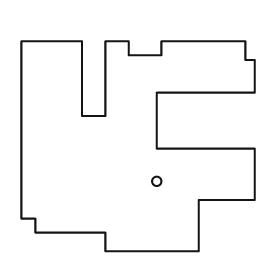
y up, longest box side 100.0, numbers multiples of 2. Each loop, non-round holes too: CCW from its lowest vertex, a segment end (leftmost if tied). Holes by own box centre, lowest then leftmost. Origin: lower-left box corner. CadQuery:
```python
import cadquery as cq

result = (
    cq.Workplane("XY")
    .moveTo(36.0, 0.0)
    .lineTo(76.0, 0.0)
    .lineTo(76.0, 22.0)
    .lineTo(100.0, 22.0)
    .lineTo(100.0, 44.0)
    .lineTo(58.0, 44.0)
    .lineTo(58.0, 68.0)
    .lineTo(100.0, 68.0)
    .lineTo(100.0, 82.0)
    .lineTo(96.0, 82.0)
    .lineTo(96.0, 90.0)
    .lineTo(60.0, 90.0)
    .lineTo(60.0, 84.0)
    .lineTo(46.0, 84.0)
    .lineTo(46.0, 90.0)
    .lineTo(36.0, 90.0)
    .lineTo(36.0, 58.0)
    .lineTo(26.0, 58.0)
    .lineTo(26.0, 90.0)
    .lineTo(0.0, 90.0)
    .lineTo(0.0, 14.0)
    .lineTo(6.0, 14.0)
    .lineTo(6.0, 8.0)
    .lineTo(36.0, 8.0)
    .close()
    .moveTo(58.0, 30.0)
    .circle(2.0)
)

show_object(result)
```